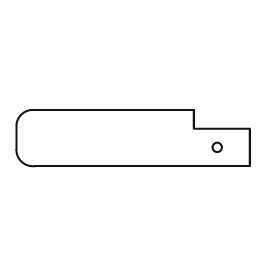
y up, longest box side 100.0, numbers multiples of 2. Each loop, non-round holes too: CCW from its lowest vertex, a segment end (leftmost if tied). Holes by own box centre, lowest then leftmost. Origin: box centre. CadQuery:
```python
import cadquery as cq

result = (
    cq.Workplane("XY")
    .moveTo(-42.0, -12.0)
    .lineTo(50.0, -12.0)
    .lineTo(50.0, 4.0)
    .lineTo(26.0, 4.0)
    .lineTo(26.0, 12.0)
    .lineTo(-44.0, 12.0)
    .threePointArc((-48.0, 10.0), (-50.0, 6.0))
    .lineTo(-50.0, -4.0)
    .threePointArc((-48.0, -10.0), (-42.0, -12.0))
    .close()
    .moveTo(36.0, -4.0)
    .circle(2.0)
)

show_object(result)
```